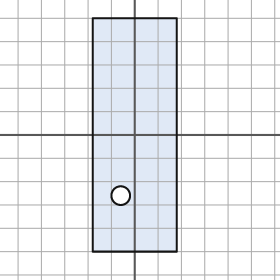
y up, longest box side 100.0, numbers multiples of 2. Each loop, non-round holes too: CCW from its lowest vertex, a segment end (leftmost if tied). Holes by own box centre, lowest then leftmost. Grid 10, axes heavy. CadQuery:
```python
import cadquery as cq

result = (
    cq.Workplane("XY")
    .moveTo(-18.0, -50.0)
    .lineTo(18.0, -50.0)
    .lineTo(18.0, 50.0)
    .lineTo(-18.0, 50.0)
    .close()
    .moveTo(-6.0, -26.0)
    .circle(4.0)
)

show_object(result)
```